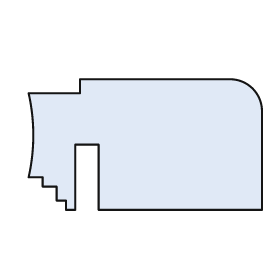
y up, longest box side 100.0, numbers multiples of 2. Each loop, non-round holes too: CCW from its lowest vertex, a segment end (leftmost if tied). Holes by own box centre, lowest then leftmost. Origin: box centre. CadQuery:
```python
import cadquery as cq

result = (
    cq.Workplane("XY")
    .moveTo(-34.0, -28.0)
    .lineTo(-30.0, -28.0)
    .lineTo(-30.0, 0.0)
    .lineTo(-20.0, 0.0)
    .lineTo(-20.0, -28.0)
    .lineTo(50.0, -28.0)
    .lineTo(50.0, 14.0)
    .threePointArc((46.0, 24.0), (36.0, 28.0))
    .lineTo(-28.0, 28.0)
    .lineTo(-28.0, 22.0)
    .lineTo(-50.0, 22.0)
    .threePointArc((-48.0, 4.0), (-50.0, -14.0))
    .lineTo(-44.0, -14.0)
    .lineTo(-44.0, -18.0)
    .lineTo(-38.0, -18.0)
    .lineTo(-38.0, -24.0)
    .lineTo(-34.0, -24.0)
    .close()
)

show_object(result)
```